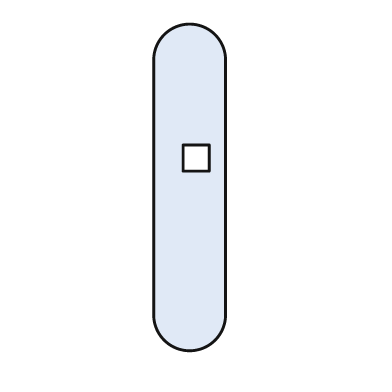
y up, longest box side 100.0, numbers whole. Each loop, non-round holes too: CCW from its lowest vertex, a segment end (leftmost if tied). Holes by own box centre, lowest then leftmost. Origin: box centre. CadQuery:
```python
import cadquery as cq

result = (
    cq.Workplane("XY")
    .moveTo(-11.0, -39.0)
    .threePointArc((0.0, -50.0), (11.0, -39.0))
    .lineTo(11.0, 39.0)
    .threePointArc((0.0, 50.0), (-11.0, 39.0))
    .close()
    .moveTo(-2.0, 5.0)
    .lineTo(6.0, 5.0)
    .lineTo(6.0, 13.0)
    .lineTo(-2.0, 13.0)
    .close()
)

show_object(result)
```